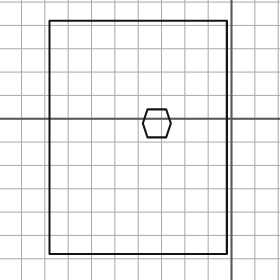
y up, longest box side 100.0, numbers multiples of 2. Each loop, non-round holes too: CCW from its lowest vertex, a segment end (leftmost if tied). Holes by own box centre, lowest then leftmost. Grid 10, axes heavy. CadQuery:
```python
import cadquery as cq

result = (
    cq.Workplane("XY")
    .moveTo(-78.0, -58.0)
    .lineTo(-2.0, -58.0)
    .lineTo(-2.0, 42.0)
    .lineTo(-78.0, 42.0)
    .close()
    .moveTo(-36.0, -8.0)
    .lineTo(-28.0, -8.0)
    .lineTo(-26.0, -2.0)
    .lineTo(-28.0, 4.0)
    .lineTo(-36.0, 4.0)
    .lineTo(-38.0, -2.0)
    .close()
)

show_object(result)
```